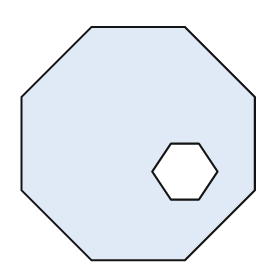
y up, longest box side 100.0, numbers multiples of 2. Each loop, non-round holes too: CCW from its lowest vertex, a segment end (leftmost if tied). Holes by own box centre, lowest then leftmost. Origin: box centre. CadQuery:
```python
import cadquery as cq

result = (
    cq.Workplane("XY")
    .moveTo(-20.0, -50.0)
    .lineTo(20.0, -50.0)
    .lineTo(50.0, -20.0)
    .lineTo(50.0, 20.0)
    .lineTo(20.0, 50.0)
    .lineTo(-20.0, 50.0)
    .lineTo(-50.0, 20.0)
    .lineTo(-50.0, -20.0)
    .close()
    .moveTo(14.0, -24.0)
    .lineTo(26.0, -24.0)
    .lineTo(34.0, -12.0)
    .lineTo(26.0, 0.0)
    .lineTo(14.0, 0.0)
    .lineTo(6.0, -12.0)
    .close()
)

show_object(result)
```